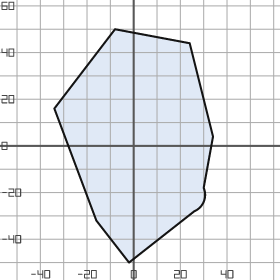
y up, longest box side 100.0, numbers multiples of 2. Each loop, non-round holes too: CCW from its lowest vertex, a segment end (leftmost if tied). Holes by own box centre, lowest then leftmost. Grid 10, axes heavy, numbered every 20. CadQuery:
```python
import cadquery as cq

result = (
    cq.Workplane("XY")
    .moveTo(-2.0, -50.0)
    .lineTo(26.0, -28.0)
    .threePointArc((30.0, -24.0), (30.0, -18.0))
    .lineTo(34.0, 4.0)
    .lineTo(24.0, 44.0)
    .lineTo(-8.0, 50.0)
    .lineTo(-34.0, 16.0)
    .lineTo(-16.0, -32.0)
    .close()
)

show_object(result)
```